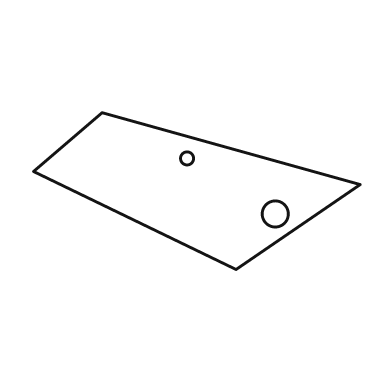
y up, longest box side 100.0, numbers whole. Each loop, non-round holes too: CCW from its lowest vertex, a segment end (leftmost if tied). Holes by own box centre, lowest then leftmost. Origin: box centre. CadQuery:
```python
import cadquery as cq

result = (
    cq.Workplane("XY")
    .moveTo(12.0, -24.0)
    .lineTo(50.0, 2.0)
    .lineTo(-29.0, 24.0)
    .lineTo(-50.0, 6.0)
    .close()
    .moveTo(24.0, -7.0)
    .circle(4.0)
    .moveTo(-3.0, 10.0)
    .circle(2.0)
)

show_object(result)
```